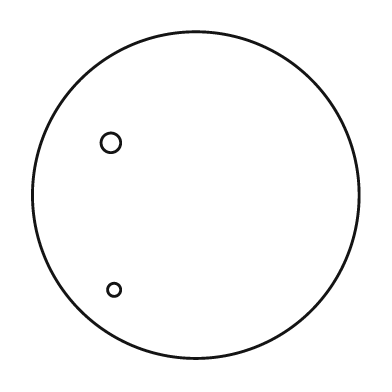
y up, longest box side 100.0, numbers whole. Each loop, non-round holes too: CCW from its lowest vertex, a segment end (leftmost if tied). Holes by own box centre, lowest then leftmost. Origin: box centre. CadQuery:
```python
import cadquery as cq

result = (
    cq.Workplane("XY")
    .moveTo(0.0, 0.0)
    .circle(50.0)
    .moveTo(-25.0, -29.0)
    .circle(2.0)
    .moveTo(-26.0, 16.0)
    .circle(3.0)
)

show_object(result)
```